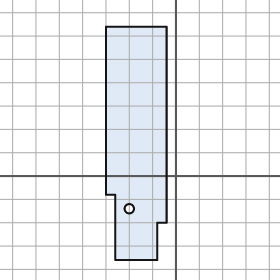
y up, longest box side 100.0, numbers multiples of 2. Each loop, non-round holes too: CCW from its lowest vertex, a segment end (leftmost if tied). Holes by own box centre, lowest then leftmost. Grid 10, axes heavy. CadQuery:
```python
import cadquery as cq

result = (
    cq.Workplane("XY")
    .moveTo(-26.0, -36.0)
    .lineTo(-8.0, -36.0)
    .lineTo(-8.0, -20.0)
    .lineTo(-4.0, -20.0)
    .lineTo(-4.0, 64.0)
    .lineTo(-30.0, 64.0)
    .lineTo(-30.0, -8.0)
    .lineTo(-26.0, -8.0)
    .close()
    .moveTo(-20.0, -14.0)
    .circle(2.0)
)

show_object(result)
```